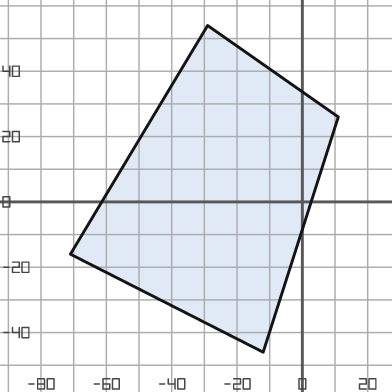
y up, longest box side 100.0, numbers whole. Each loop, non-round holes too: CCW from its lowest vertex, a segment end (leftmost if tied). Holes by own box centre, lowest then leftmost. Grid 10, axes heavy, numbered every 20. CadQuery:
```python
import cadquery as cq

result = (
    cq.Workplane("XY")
    .moveTo(-12.0, -46.0)
    .lineTo(11.0, 26.0)
    .lineTo(-29.0, 54.0)
    .lineTo(-71.0, -16.0)
    .close()
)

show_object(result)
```